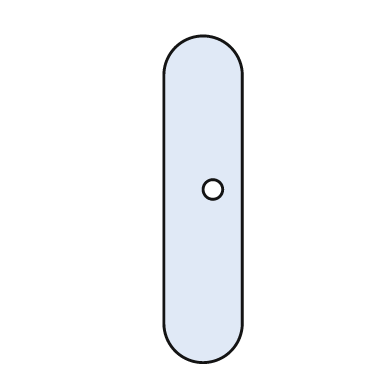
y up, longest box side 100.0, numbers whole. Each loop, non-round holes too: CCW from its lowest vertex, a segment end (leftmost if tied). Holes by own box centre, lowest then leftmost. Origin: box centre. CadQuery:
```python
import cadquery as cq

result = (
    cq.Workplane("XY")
    .moveTo(-12.0, -38.0)
    .threePointArc((0.0, -50.0), (12.0, -38.0))
    .lineTo(12.0, 38.0)
    .threePointArc((0.0, 50.0), (-12.0, 38.0))
    .close()
    .moveTo(3.0, 3.0)
    .circle(3.0)
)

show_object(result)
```